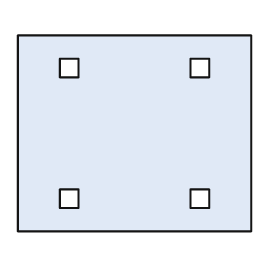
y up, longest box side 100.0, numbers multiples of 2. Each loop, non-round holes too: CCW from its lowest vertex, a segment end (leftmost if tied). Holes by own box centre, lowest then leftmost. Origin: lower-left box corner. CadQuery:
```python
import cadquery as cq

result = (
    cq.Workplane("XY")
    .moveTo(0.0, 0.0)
    .lineTo(100.0, 0.0)
    .lineTo(100.0, 84.0)
    .lineTo(0.0, 84.0)
    .close()
    .moveTo(18.0, 10.0)
    .lineTo(26.0, 10.0)
    .lineTo(26.0, 18.0)
    .lineTo(18.0, 18.0)
    .close()
    .moveTo(74.0, 10.0)
    .lineTo(82.0, 10.0)
    .lineTo(82.0, 18.0)
    .lineTo(74.0, 18.0)
    .close()
    .moveTo(18.0, 66.0)
    .lineTo(26.0, 66.0)
    .lineTo(26.0, 74.0)
    .lineTo(18.0, 74.0)
    .close()
    .moveTo(74.0, 66.0)
    .lineTo(82.0, 66.0)
    .lineTo(82.0, 74.0)
    .lineTo(74.0, 74.0)
    .close()
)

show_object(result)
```